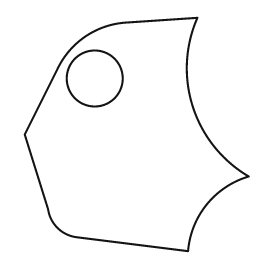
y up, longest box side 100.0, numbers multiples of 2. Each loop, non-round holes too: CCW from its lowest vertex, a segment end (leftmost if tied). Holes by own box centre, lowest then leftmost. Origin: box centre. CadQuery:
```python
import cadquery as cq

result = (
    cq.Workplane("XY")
    .moveTo(22.0, -50.0)
    .threePointArc((30.0, -30.0), (48.0, -18.0))
    .threePointArc((24.0, 12.0), (26.0, 50.0))
    .lineTo(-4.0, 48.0)
    .threePointArc((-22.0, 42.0), (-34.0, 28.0))
    .lineTo(-48.0, 0.0)
    .lineTo(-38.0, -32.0)
    .threePointArc((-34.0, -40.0), (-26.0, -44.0))
    .close()
    .moveTo(-18.0, 24.0)
    .circle(12.0)
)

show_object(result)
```